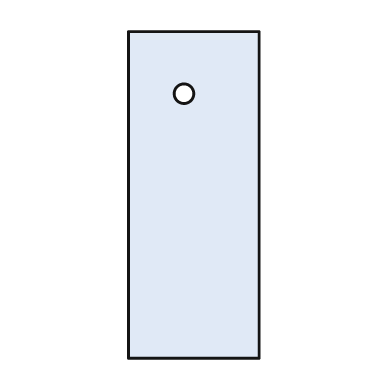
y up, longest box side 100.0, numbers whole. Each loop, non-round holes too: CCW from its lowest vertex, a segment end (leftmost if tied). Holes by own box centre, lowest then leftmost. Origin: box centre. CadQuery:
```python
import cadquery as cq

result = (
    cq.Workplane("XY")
    .moveTo(-20.0, -50.0)
    .lineTo(20.0, -50.0)
    .lineTo(20.0, 50.0)
    .lineTo(-20.0, 50.0)
    .close()
    .moveTo(-3.0, 31.0)
    .circle(3.0)
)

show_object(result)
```